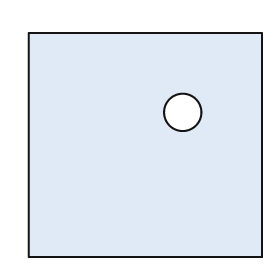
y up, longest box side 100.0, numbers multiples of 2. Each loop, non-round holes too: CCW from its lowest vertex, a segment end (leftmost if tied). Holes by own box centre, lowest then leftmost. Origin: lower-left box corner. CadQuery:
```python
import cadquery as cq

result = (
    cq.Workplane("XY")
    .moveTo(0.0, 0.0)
    .lineTo(100.0, 0.0)
    .lineTo(100.0, 96.0)
    .lineTo(0.0, 96.0)
    .close()
    .moveTo(66.0, 62.0)
    .circle(8.0)
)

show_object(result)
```